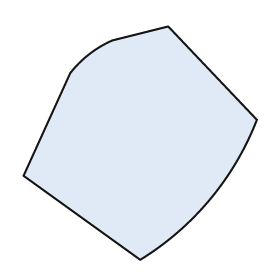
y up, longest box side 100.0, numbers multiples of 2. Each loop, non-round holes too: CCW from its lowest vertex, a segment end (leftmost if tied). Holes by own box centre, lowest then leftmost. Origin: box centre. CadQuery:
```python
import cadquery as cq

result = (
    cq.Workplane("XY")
    .moveTo(0.0, -50.0)
    .threePointArc((30.0, -24.0), (50.0, 10.0))
    .lineTo(12.0, 50.0)
    .lineTo(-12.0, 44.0)
    .threePointArc((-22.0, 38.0), (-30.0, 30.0))
    .lineTo(-50.0, -14.0)
    .close()
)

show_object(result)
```